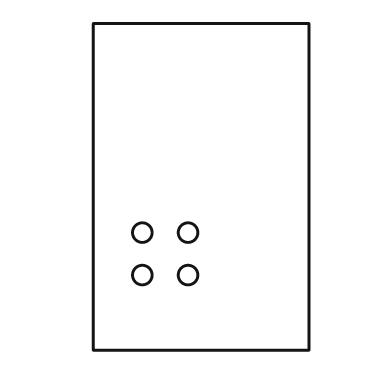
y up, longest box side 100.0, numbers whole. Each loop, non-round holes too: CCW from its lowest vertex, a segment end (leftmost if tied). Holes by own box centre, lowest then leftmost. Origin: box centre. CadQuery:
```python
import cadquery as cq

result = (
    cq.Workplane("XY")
    .moveTo(-33.0, -50.0)
    .lineTo(33.0, -50.0)
    .lineTo(33.0, 50.0)
    .lineTo(-33.0, 50.0)
    .close()
    .moveTo(-18.0, -27.0)
    .circle(3.0)
    .moveTo(-4.0, -27.0)
    .circle(3.0)
    .moveTo(-18.0, -14.0)
    .circle(3.0)
    .moveTo(-4.0, -14.0)
    .circle(3.0)
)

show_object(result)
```